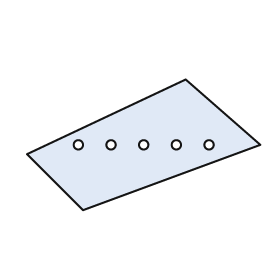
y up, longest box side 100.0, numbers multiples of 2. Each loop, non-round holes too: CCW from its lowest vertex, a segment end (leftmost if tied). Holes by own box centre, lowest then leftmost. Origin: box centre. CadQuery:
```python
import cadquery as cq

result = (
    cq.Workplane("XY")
    .moveTo(-26.0, -28.0)
    .lineTo(50.0, 0.0)
    .lineTo(18.0, 28.0)
    .lineTo(-50.0, -4.0)
    .close()
    .moveTo(-28.0, 0.0)
    .circle(2.0)
    .moveTo(-14.0, 0.0)
    .circle(2.0)
    .moveTo(0.0, 0.0)
    .circle(2.0)
    .moveTo(14.0, 0.0)
    .circle(2.0)
    .moveTo(28.0, 0.0)
    .circle(2.0)
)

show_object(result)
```